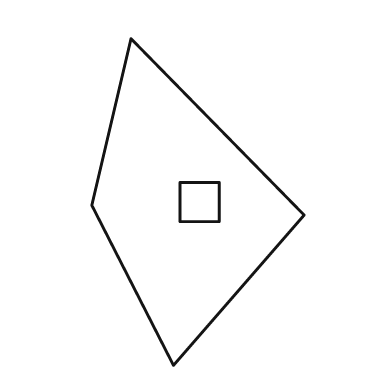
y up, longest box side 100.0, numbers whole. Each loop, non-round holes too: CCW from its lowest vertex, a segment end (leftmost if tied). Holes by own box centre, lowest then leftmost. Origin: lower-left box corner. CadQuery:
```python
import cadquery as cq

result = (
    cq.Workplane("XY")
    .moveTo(25.0, 0.0)
    .lineTo(65.0, 46.0)
    .lineTo(12.0, 100.0)
    .lineTo(0.0, 49.0)
    .close()
    .moveTo(27.0, 44.0)
    .lineTo(39.0, 44.0)
    .lineTo(39.0, 56.0)
    .lineTo(27.0, 56.0)
    .close()
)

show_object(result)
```